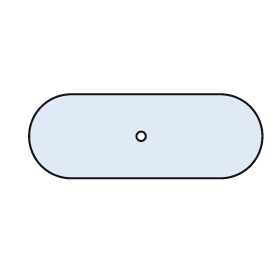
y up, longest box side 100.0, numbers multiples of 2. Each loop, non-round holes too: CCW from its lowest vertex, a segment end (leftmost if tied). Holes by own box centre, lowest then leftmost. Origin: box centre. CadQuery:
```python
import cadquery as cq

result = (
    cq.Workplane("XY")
    .moveTo(-32.0, -18.0)
    .lineTo(32.0, -18.0)
    .threePointArc((50.0, 0.0), (32.0, 18.0))
    .lineTo(-32.0, 18.0)
    .threePointArc((-50.0, 0.0), (-32.0, -18.0))
    .close()
    .moveTo(-2.0, 0.0)
    .circle(2.0)
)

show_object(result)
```